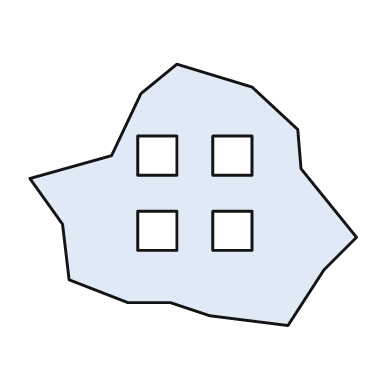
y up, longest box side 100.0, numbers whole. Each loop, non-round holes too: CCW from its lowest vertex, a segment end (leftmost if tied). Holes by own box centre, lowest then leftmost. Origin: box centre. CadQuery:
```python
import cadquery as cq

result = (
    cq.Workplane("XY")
    .moveTo(29.0, -40.0)
    .lineTo(40.0, -23.0)
    .lineTo(50.0, -13.0)
    .lineTo(33.0, 8.0)
    .lineTo(32.0, 20.0)
    .lineTo(18.0, 33.0)
    .lineTo(-5.0, 40.0)
    .lineTo(-16.0, 31.0)
    .lineTo(-25.0, 12.0)
    .lineTo(-50.0, 5.0)
    .lineTo(-40.0, -9.0)
    .lineTo(-38.0, -26.0)
    .lineTo(-20.0, -33.0)
    .lineTo(-7.0, -33.0)
    .lineTo(5.0, -37.0)
    .close()
    .moveTo(-17.0, -17.0)
    .lineTo(-5.0, -17.0)
    .lineTo(-5.0, -5.0)
    .lineTo(-17.0, -5.0)
    .close()
    .moveTo(6.0, -17.0)
    .lineTo(18.0, -17.0)
    .lineTo(18.0, -5.0)
    .lineTo(6.0, -5.0)
    .close()
    .moveTo(-17.0, 6.0)
    .lineTo(-5.0, 6.0)
    .lineTo(-5.0, 18.0)
    .lineTo(-17.0, 18.0)
    .close()
    .moveTo(6.0, 6.0)
    .lineTo(18.0, 6.0)
    .lineTo(18.0, 18.0)
    .lineTo(6.0, 18.0)
    .close()
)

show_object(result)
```